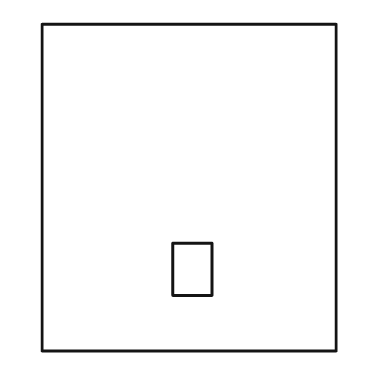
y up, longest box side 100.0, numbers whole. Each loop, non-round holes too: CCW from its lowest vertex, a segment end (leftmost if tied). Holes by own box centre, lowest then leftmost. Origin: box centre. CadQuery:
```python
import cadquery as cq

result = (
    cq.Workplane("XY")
    .moveTo(-45.0, -50.0)
    .lineTo(45.0, -50.0)
    .lineTo(45.0, 50.0)
    .lineTo(-45.0, 50.0)
    .close()
    .moveTo(-5.0, -33.0)
    .lineTo(7.0, -33.0)
    .lineTo(7.0, -17.0)
    .lineTo(-5.0, -17.0)
    .close()
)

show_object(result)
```